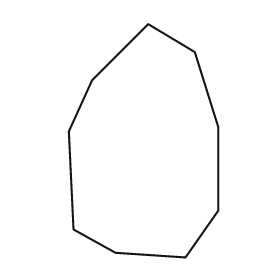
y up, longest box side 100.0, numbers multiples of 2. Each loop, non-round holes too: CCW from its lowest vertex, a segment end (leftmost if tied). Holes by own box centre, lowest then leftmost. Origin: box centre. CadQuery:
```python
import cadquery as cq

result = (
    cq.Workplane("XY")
    .moveTo(18.0, -50.0)
    .lineTo(32.0, -30.0)
    .lineTo(32.0, 6.0)
    .lineTo(22.0, 38.0)
    .lineTo(2.0, 50.0)
    .lineTo(-22.0, 26.0)
    .lineTo(-32.0, 4.0)
    .lineTo(-30.0, -38.0)
    .lineTo(-12.0, -48.0)
    .close()
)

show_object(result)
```